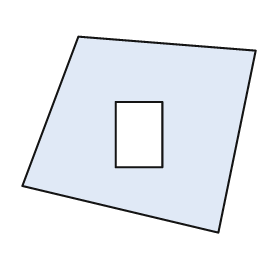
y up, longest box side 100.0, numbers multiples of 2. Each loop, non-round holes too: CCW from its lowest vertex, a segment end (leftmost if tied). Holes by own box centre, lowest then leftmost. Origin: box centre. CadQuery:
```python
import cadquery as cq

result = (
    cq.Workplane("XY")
    .moveTo(34.0, -42.0)
    .lineTo(50.0, 36.0)
    .lineTo(-26.0, 42.0)
    .lineTo(-50.0, -22.0)
    .close()
    .moveTo(-10.0, -14.0)
    .lineTo(10.0, -14.0)
    .lineTo(10.0, 14.0)
    .lineTo(-10.0, 14.0)
    .close()
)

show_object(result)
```